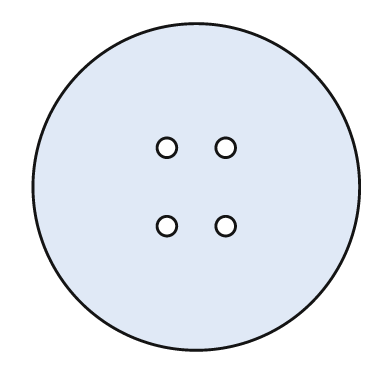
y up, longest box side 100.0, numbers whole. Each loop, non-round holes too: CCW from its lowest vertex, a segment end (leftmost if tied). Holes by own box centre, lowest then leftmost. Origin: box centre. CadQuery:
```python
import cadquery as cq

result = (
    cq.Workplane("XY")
    .moveTo(0.0, 0.0)
    .circle(50.0)
    .moveTo(-9.0, -12.0)
    .circle(3.0)
    .moveTo(9.0, -12.0)
    .circle(3.0)
    .moveTo(-9.0, 12.0)
    .circle(3.0)
    .moveTo(9.0, 12.0)
    .circle(3.0)
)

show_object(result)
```